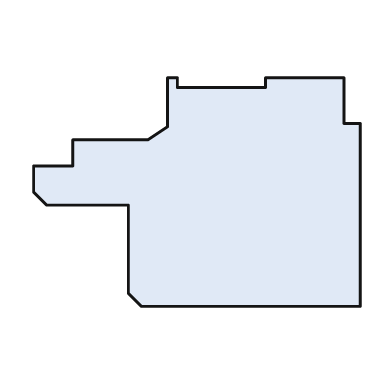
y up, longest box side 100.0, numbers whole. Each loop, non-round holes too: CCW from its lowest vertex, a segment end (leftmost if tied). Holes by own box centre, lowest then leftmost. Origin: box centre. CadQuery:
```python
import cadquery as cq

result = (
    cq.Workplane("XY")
    .moveTo(-17.0, -35.0)
    .lineTo(50.0, -35.0)
    .lineTo(50.0, 21.0)
    .lineTo(45.0, 21.0)
    .lineTo(45.0, 35.0)
    .lineTo(21.0, 35.0)
    .lineTo(21.0, 32.0)
    .lineTo(-6.0, 32.0)
    .lineTo(-6.0, 35.0)
    .lineTo(-9.0, 35.0)
    .lineTo(-9.0, 20.0)
    .lineTo(-15.0, 16.0)
    .lineTo(-38.0, 16.0)
    .lineTo(-38.0, 8.0)
    .lineTo(-50.0, 8.0)
    .lineTo(-50.0, 0.0)
    .lineTo(-46.0, -4.0)
    .lineTo(-21.0, -4.0)
    .lineTo(-21.0, -31.0)
    .close()
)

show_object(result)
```